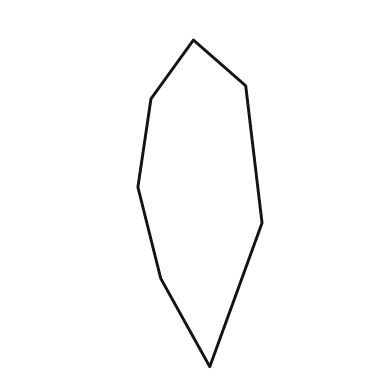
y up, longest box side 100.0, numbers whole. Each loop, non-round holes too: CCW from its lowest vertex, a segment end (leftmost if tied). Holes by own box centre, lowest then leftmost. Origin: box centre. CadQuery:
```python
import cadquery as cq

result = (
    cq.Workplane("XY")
    .moveTo(3.0, -50.0)
    .lineTo(19.0, -6.0)
    .lineTo(14.0, 36.0)
    .lineTo(-2.0, 50.0)
    .lineTo(-15.0, 32.0)
    .lineTo(-19.0, 5.0)
    .lineTo(-12.0, -23.0)
    .close()
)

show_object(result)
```